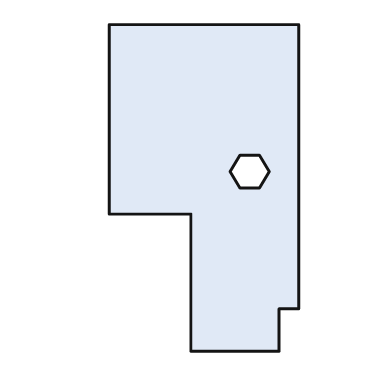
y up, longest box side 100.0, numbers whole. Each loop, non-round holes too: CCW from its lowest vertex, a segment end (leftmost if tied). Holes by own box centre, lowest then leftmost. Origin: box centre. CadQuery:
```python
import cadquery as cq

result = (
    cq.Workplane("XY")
    .moveTo(-4.0, -50.0)
    .lineTo(23.0, -50.0)
    .lineTo(23.0, -37.0)
    .lineTo(29.0, -37.0)
    .lineTo(29.0, 50.0)
    .lineTo(-29.0, 50.0)
    .lineTo(-29.0, -8.0)
    .lineTo(-4.0, -8.0)
    .close()
    .moveTo(11.0, 0.0)
    .lineTo(17.0, 0.0)
    .lineTo(20.0, 5.0)
    .lineTo(17.0, 10.0)
    .lineTo(11.0, 10.0)
    .lineTo(8.0, 5.0)
    .close()
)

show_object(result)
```